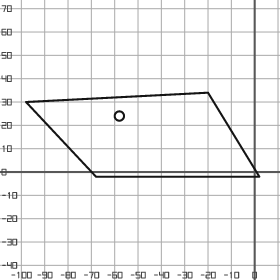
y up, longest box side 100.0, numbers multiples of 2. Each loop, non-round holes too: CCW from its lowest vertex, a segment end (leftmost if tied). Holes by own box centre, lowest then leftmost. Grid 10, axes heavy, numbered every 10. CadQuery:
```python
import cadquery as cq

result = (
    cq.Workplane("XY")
    .moveTo(-68.0, -2.0)
    .lineTo(2.0, -2.0)
    .lineTo(-20.0, 34.0)
    .lineTo(-98.0, 30.0)
    .close()
    .moveTo(-58.0, 24.0)
    .circle(2.0)
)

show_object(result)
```